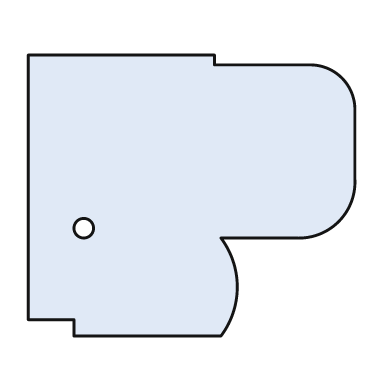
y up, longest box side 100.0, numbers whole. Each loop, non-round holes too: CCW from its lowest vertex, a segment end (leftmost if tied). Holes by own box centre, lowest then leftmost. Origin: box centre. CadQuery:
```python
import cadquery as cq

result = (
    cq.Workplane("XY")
    .moveTo(-36.0, -43.0)
    .lineTo(9.0, -43.0)
    .threePointArc((14.0, -28.0), (9.0, -13.0))
    .lineTo(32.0, -13.0)
    .threePointArc((45.0, -8.0), (50.0, 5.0))
    .lineTo(50.0, 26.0)
    .threePointArc((46.0, 36.0), (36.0, 40.0))
    .lineTo(7.0, 40.0)
    .lineTo(7.0, 43.0)
    .lineTo(-50.0, 43.0)
    .lineTo(-50.0, -38.0)
    .lineTo(-36.0, -38.0)
    .close()
    .moveTo(-33.0, -10.0)
    .circle(3.0)
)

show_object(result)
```